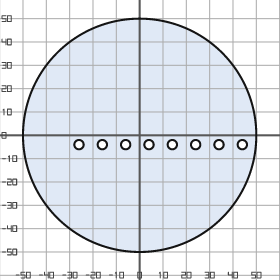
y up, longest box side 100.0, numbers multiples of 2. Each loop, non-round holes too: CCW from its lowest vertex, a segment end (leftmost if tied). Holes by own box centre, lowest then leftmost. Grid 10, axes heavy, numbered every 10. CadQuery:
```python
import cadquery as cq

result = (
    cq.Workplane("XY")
    .moveTo(0.0, 0.0)
    .circle(50.0)
    .moveTo(-26.0, -4.0)
    .circle(2.0)
    .moveTo(-16.0, -4.0)
    .circle(2.0)
    .moveTo(-6.0, -4.0)
    .circle(2.0)
    .moveTo(4.0, -4.0)
    .circle(2.0)
    .moveTo(14.0, -4.0)
    .circle(2.0)
    .moveTo(24.0, -4.0)
    .circle(2.0)
    .moveTo(34.0, -4.0)
    .circle(2.0)
    .moveTo(44.0, -4.0)
    .circle(2.0)
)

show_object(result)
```